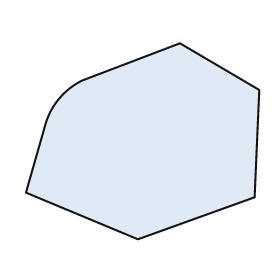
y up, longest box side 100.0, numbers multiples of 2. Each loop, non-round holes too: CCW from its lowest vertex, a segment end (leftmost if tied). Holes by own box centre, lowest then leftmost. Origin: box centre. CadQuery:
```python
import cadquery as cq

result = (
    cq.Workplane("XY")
    .moveTo(-2.0, -42.0)
    .lineTo(48.0, -24.0)
    .lineTo(50.0, 22.0)
    .lineTo(16.0, 42.0)
    .lineTo(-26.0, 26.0)
    .threePointArc((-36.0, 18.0), (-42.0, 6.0))
    .lineTo(-50.0, -22.0)
    .close()
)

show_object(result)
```